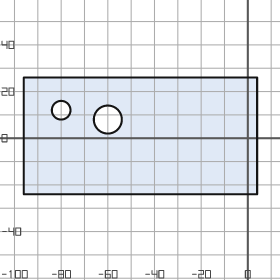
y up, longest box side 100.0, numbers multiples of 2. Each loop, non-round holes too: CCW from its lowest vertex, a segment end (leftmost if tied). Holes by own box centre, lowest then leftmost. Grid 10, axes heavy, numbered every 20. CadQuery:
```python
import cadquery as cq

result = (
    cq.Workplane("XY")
    .moveTo(-96.0, -24.0)
    .lineTo(4.0, -24.0)
    .lineTo(4.0, 26.0)
    .lineTo(-96.0, 26.0)
    .close()
    .moveTo(-60.0, 8.0)
    .circle(6.0)
    .moveTo(-80.0, 12.0)
    .circle(4.0)
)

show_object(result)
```